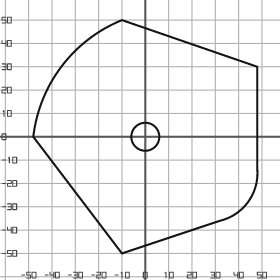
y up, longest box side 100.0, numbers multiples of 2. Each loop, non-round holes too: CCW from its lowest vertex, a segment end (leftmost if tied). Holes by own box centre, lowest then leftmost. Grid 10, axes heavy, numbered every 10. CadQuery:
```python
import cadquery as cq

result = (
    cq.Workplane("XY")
    .moveTo(-10.0, -50.0)
    .lineTo(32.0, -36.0)
    .threePointArc((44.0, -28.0), (48.0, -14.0))
    .lineTo(48.0, 30.0)
    .lineTo(-10.0, 50.0)
    .threePointArc((-36.0, 30.0), (-48.0, 0.0))
    .close()
    .moveTo(0.0, 0.0)
    .circle(6.0)
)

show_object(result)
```